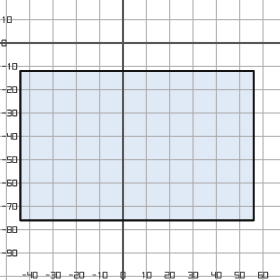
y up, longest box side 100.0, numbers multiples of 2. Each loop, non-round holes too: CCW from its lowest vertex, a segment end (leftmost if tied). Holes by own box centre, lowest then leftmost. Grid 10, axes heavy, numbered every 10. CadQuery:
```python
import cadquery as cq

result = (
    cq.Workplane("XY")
    .moveTo(-44.0, -76.0)
    .lineTo(56.0, -76.0)
    .lineTo(56.0, -12.0)
    .lineTo(-44.0, -12.0)
    .close()
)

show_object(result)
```